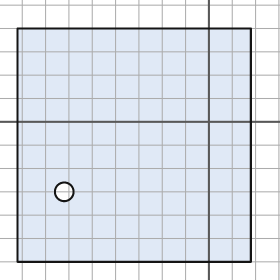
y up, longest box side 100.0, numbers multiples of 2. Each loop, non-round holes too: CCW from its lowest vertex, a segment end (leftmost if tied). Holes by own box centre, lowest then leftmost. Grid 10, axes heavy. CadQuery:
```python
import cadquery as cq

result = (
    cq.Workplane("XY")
    .moveTo(-82.0, -60.0)
    .lineTo(18.0, -60.0)
    .lineTo(18.0, 40.0)
    .lineTo(-82.0, 40.0)
    .close()
    .moveTo(-62.0, -30.0)
    .circle(4.0)
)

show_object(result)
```